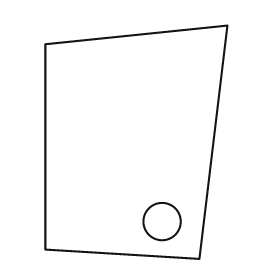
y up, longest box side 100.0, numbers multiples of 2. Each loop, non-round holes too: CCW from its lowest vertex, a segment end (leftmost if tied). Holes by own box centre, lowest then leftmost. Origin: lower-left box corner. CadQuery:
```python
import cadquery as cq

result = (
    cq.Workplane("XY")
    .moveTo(66.0, 0.0)
    .lineTo(78.0, 100.0)
    .lineTo(0.0, 92.0)
    .lineTo(0.0, 4.0)
    .close()
    .moveTo(50.0, 16.0)
    .circle(8.0)
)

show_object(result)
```